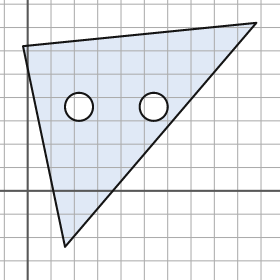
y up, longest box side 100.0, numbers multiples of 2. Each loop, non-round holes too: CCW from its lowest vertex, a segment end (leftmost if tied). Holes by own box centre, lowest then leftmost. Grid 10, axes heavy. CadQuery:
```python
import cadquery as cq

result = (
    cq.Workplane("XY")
    .moveTo(16.0, -24.0)
    .lineTo(98.0, 72.0)
    .lineTo(-2.0, 62.0)
    .close()
    .moveTo(22.0, 36.0)
    .circle(6.0)
    .moveTo(54.0, 36.0)
    .circle(6.0)
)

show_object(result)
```